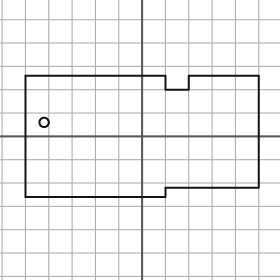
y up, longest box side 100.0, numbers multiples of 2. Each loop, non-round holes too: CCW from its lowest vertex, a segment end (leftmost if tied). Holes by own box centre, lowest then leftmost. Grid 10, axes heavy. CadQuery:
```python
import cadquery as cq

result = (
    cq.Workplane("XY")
    .moveTo(-50.0, -26.0)
    .lineTo(10.0, -26.0)
    .lineTo(10.0, -22.0)
    .lineTo(50.0, -22.0)
    .lineTo(50.0, 26.0)
    .lineTo(20.0, 26.0)
    .lineTo(20.0, 20.0)
    .lineTo(10.0, 20.0)
    .lineTo(10.0, 26.0)
    .lineTo(-50.0, 26.0)
    .close()
    .moveTo(-42.0, 6.0)
    .circle(2.0)
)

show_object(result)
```